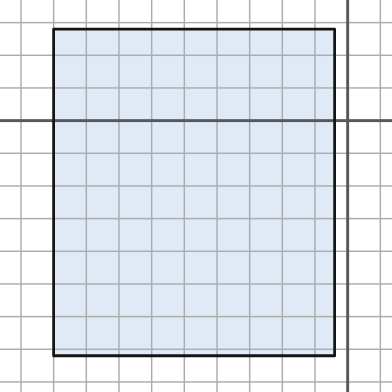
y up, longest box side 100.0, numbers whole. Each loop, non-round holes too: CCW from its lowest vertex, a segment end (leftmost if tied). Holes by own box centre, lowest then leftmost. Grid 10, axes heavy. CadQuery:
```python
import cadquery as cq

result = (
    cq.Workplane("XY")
    .moveTo(-90.0, -72.0)
    .lineTo(-4.0, -72.0)
    .lineTo(-4.0, 28.0)
    .lineTo(-90.0, 28.0)
    .close()
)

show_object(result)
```